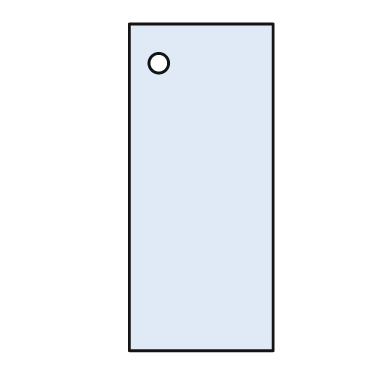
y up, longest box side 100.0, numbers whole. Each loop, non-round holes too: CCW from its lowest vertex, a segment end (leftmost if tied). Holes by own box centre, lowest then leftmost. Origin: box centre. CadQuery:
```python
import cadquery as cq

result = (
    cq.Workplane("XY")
    .moveTo(-22.0, -50.0)
    .lineTo(22.0, -50.0)
    .lineTo(22.0, 50.0)
    .lineTo(-22.0, 50.0)
    .close()
    .moveTo(-13.0, 38.0)
    .circle(3.0)
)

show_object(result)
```